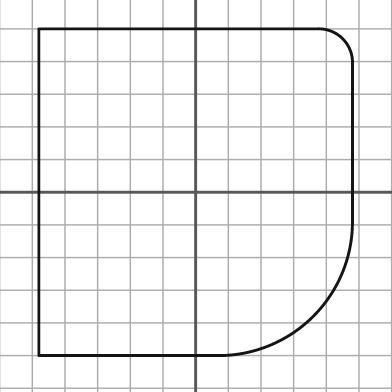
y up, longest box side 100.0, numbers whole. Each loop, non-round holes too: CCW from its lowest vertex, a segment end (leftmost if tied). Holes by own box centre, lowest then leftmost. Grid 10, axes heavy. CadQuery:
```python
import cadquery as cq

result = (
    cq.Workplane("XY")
    .moveTo(-48.0, -50.0)
    .lineTo(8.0, -50.0)
    .threePointArc((36.0, -38.0), (48.0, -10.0))
    .lineTo(48.0, 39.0)
    .threePointArc((45.0, 47.0), (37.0, 50.0))
    .lineTo(-48.0, 50.0)
    .close()
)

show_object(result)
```